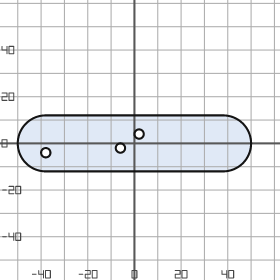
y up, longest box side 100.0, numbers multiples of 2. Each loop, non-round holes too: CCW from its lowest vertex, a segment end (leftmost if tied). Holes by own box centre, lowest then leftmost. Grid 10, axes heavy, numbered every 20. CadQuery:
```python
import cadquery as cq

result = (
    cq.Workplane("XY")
    .moveTo(-38.0, -12.0)
    .lineTo(38.0, -12.0)
    .threePointArc((50.0, 0.0), (38.0, 12.0))
    .lineTo(-38.0, 12.0)
    .threePointArc((-50.0, 0.0), (-38.0, -12.0))
    .close()
    .moveTo(-38.0, -4.0)
    .circle(2.0)
    .moveTo(-6.0, -2.0)
    .circle(2.0)
    .moveTo(2.0, 4.0)
    .circle(2.0)
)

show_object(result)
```